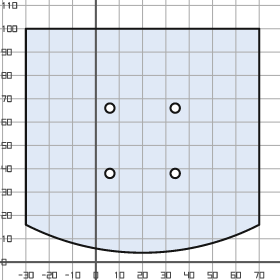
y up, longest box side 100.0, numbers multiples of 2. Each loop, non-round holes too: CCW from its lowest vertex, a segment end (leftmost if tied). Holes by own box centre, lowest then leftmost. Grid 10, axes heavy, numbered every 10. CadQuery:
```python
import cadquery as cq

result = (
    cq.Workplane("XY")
    .moveTo(-30.0, 16.0)
    .threePointArc((20.0, 4.0), (70.0, 16.0))
    .lineTo(70.0, 100.0)
    .lineTo(-30.0, 100.0)
    .close()
    .moveTo(6.0, 38.0)
    .circle(2.0)
    .moveTo(34.0, 38.0)
    .circle(2.0)
    .moveTo(6.0, 66.0)
    .circle(2.0)
    .moveTo(34.0, 66.0)
    .circle(2.0)
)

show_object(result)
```